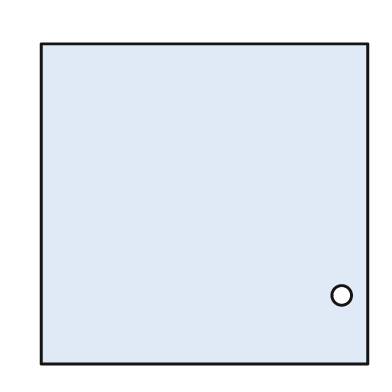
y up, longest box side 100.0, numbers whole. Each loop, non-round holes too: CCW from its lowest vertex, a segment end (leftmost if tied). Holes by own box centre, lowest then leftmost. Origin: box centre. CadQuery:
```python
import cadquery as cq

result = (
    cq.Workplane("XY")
    .moveTo(-50.0, -49.0)
    .lineTo(50.0, -49.0)
    .lineTo(50.0, 49.0)
    .lineTo(-50.0, 49.0)
    .close()
    .moveTo(42.0, -28.0)
    .circle(3.0)
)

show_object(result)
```